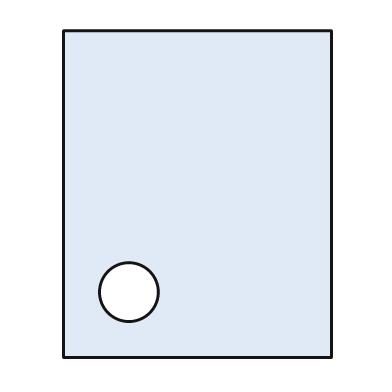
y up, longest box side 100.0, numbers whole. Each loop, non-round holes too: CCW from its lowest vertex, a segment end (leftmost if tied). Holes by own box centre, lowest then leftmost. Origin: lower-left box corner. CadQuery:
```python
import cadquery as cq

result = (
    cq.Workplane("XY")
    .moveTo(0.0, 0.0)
    .lineTo(82.0, 0.0)
    .lineTo(82.0, 100.0)
    .lineTo(0.0, 100.0)
    .close()
    .moveTo(20.0, 20.0)
    .circle(9.0)
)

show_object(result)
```